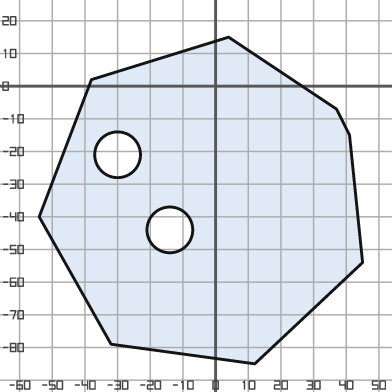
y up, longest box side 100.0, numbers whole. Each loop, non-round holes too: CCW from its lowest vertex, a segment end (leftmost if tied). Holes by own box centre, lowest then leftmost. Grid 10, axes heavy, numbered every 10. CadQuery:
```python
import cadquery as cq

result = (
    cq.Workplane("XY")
    .moveTo(12.0, -85.0)
    .lineTo(45.0, -54.0)
    .lineTo(41.0, -15.0)
    .lineTo(37.0, -7.0)
    .lineTo(4.0, 15.0)
    .lineTo(-38.0, 2.0)
    .lineTo(-54.0, -40.0)
    .lineTo(-32.0, -79.0)
    .close()
    .moveTo(-14.0, -44.0)
    .circle(7.0)
    .moveTo(-30.0, -21.0)
    .circle(7.0)
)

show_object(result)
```